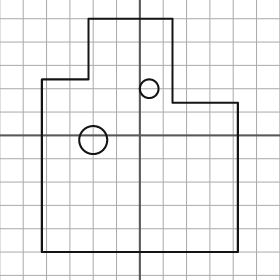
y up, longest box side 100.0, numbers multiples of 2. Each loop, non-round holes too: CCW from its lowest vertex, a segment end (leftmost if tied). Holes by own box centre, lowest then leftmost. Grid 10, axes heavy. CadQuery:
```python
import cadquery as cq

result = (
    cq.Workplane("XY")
    .moveTo(-42.0, -50.0)
    .lineTo(42.0, -50.0)
    .lineTo(42.0, 14.0)
    .lineTo(14.0, 14.0)
    .lineTo(14.0, 50.0)
    .lineTo(-22.0, 50.0)
    .lineTo(-22.0, 24.0)
    .lineTo(-42.0, 24.0)
    .close()
    .moveTo(-20.0, -2.0)
    .circle(6.0)
    .moveTo(4.0, 20.0)
    .circle(4.0)
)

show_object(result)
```